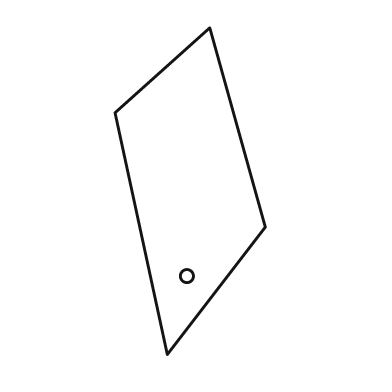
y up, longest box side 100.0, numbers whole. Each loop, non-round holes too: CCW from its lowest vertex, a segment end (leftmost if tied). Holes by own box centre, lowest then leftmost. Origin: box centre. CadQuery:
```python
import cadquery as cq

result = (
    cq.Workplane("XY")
    .moveTo(-7.0, -50.0)
    .lineTo(23.0, -11.0)
    .lineTo(6.0, 50.0)
    .lineTo(-23.0, 24.0)
    .close()
    .moveTo(-1.0, -26.0)
    .circle(2.0)
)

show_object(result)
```